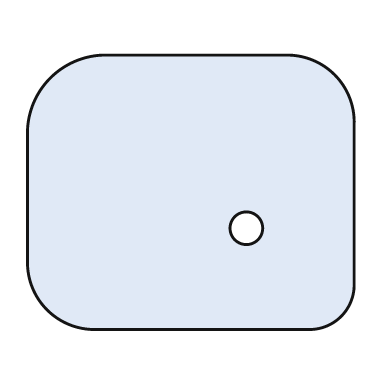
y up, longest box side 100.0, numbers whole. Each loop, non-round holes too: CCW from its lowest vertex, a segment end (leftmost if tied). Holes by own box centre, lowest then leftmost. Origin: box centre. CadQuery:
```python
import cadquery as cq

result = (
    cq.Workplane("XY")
    .moveTo(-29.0, -42.0)
    .lineTo(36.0, -42.0)
    .threePointArc((46.0, -38.0), (50.0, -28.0))
    .lineTo(50.0, 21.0)
    .threePointArc((44.0, 36.0), (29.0, 42.0))
    .lineTo(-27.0, 42.0)
    .threePointArc((-43.0, 35.0), (-50.0, 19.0))
    .lineTo(-50.0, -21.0)
    .threePointArc((-44.0, -36.0), (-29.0, -42.0))
    .close()
    .moveTo(17.0, -11.0)
    .circle(5.0)
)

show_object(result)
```